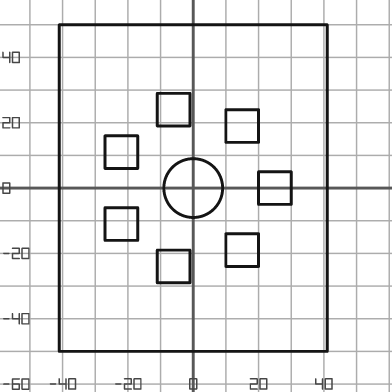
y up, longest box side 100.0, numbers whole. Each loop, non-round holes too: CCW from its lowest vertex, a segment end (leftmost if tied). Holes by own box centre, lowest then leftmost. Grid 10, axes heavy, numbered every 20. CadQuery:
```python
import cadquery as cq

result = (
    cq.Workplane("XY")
    .moveTo(-41.0, -50.0)
    .lineTo(41.0, -50.0)
    .lineTo(41.0, 50.0)
    .lineTo(-41.0, 50.0)
    .close()
    .moveTo(-11.0, -29.0)
    .lineTo(-1.0, -29.0)
    .lineTo(-1.0, -19.0)
    .lineTo(-11.0, -19.0)
    .close()
    .moveTo(10.0, -24.0)
    .lineTo(20.0, -24.0)
    .lineTo(20.0, -14.0)
    .lineTo(10.0, -14.0)
    .close()
    .moveTo(-27.0, -16.0)
    .lineTo(-17.0, -16.0)
    .lineTo(-17.0, -6.0)
    .lineTo(-27.0, -6.0)
    .close()
    .moveTo(0.0, 0.0)
    .circle(9.0)
    .moveTo(20.0, -5.0)
    .lineTo(30.0, -5.0)
    .lineTo(30.0, 5.0)
    .lineTo(20.0, 5.0)
    .close()
    .moveTo(-27.0, 6.0)
    .lineTo(-17.0, 6.0)
    .lineTo(-17.0, 16.0)
    .lineTo(-27.0, 16.0)
    .close()
    .moveTo(10.0, 14.0)
    .lineTo(20.0, 14.0)
    .lineTo(20.0, 24.0)
    .lineTo(10.0, 24.0)
    .close()
    .moveTo(-11.0, 19.0)
    .lineTo(-1.0, 19.0)
    .lineTo(-1.0, 29.0)
    .lineTo(-11.0, 29.0)
    .close()
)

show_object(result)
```